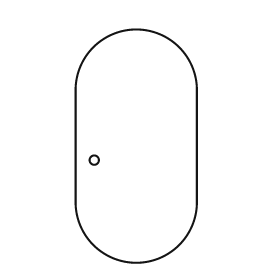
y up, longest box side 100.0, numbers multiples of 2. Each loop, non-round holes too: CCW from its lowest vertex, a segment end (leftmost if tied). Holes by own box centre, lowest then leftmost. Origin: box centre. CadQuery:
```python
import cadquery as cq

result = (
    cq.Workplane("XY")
    .moveTo(-26.0, -24.0)
    .threePointArc((0.0, -50.0), (26.0, -24.0))
    .lineTo(26.0, 24.0)
    .threePointArc((0.0, 50.0), (-26.0, 24.0))
    .close()
    .moveTo(-18.0, -6.0)
    .circle(2.0)
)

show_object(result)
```